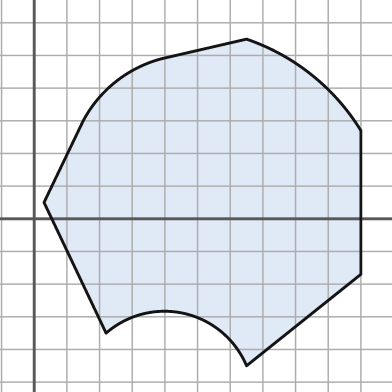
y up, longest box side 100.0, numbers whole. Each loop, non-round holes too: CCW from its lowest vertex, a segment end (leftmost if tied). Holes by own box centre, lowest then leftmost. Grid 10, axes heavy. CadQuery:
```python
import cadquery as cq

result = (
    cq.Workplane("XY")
    .moveTo(65.0, -45.0)
    .lineTo(100.0, -17.0)
    .lineTo(100.0, 27.0)
    .threePointArc((85.0, 44.0), (65.0, 55.0))
    .lineTo(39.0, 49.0)
    .threePointArc((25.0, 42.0), (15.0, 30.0))
    .lineTo(3.0, 5.0)
    .lineTo(22.0, -35.0)
    .threePointArc((46.0, -29.0), (65.0, -45.0))
    .close()
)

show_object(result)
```